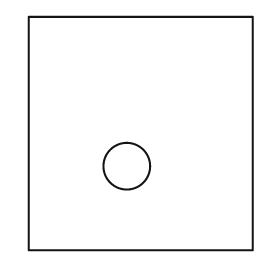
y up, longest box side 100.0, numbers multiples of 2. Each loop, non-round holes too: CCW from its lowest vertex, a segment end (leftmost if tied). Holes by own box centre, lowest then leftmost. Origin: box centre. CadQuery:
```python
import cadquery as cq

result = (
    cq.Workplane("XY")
    .moveTo(-48.0, -50.0)
    .lineTo(48.0, -50.0)
    .lineTo(48.0, 50.0)
    .lineTo(-48.0, 50.0)
    .close()
    .moveTo(-6.0, -14.0)
    .circle(10.0)
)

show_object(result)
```